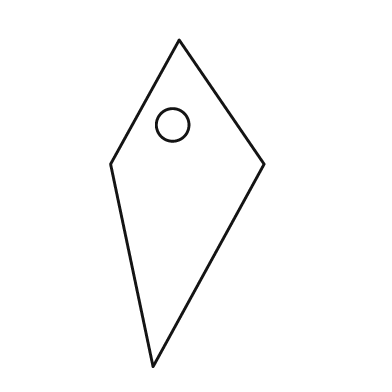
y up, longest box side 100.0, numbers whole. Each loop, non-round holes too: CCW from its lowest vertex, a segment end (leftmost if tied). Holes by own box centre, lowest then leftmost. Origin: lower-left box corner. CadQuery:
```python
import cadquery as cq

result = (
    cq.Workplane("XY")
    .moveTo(13.0, 0.0)
    .lineTo(47.0, 62.0)
    .lineTo(21.0, 100.0)
    .lineTo(0.0, 62.0)
    .close()
    .moveTo(19.0, 74.0)
    .circle(5.0)
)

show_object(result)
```